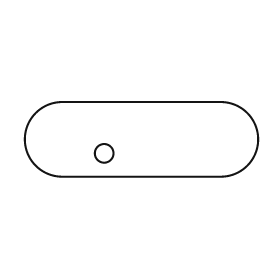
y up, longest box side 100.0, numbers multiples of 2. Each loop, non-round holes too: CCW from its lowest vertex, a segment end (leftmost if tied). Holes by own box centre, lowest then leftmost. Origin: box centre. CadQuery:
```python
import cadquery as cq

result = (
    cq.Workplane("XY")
    .moveTo(-34.0, -16.0)
    .lineTo(34.0, -16.0)
    .threePointArc((50.0, 0.0), (34.0, 16.0))
    .lineTo(-34.0, 16.0)
    .threePointArc((-50.0, 0.0), (-34.0, -16.0))
    .close()
    .moveTo(-16.0, -6.0)
    .circle(4.0)
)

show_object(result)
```